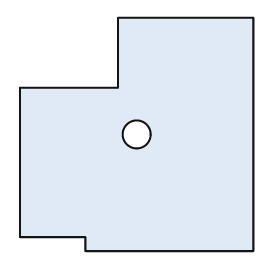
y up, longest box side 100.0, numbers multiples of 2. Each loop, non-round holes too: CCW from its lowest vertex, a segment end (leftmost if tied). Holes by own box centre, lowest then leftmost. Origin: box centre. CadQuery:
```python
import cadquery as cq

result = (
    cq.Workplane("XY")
    .moveTo(-22.0, -50.0)
    .lineTo(50.0, -50.0)
    .lineTo(50.0, 50.0)
    .lineTo(-8.0, 50.0)
    .lineTo(-8.0, 20.0)
    .lineTo(-50.0, 20.0)
    .lineTo(-50.0, -44.0)
    .lineTo(-22.0, -44.0)
    .close()
    .moveTo(0.0, 0.0)
    .circle(6.0)
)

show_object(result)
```